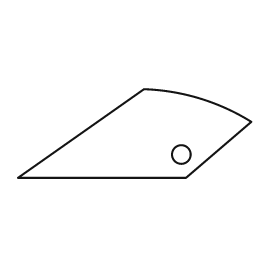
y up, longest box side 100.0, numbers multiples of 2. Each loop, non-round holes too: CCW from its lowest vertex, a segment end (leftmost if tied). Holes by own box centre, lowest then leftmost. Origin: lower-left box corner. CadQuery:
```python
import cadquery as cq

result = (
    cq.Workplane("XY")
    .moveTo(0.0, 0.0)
    .lineTo(72.0, 0.0)
    .lineTo(100.0, 24.0)
    .threePointArc((78.0, 34.0), (54.0, 38.0))
    .close()
    .moveTo(70.0, 10.0)
    .circle(4.0)
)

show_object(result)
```